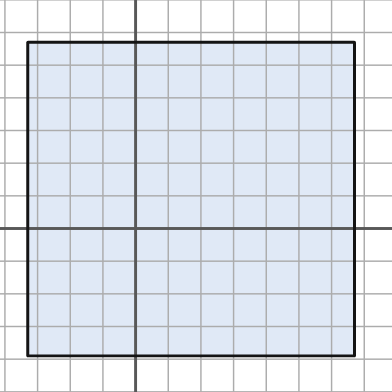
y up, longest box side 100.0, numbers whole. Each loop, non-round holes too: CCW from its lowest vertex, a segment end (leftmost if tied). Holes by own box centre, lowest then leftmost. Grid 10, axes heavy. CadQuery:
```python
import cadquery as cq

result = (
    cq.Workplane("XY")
    .moveTo(-33.0, -39.0)
    .lineTo(67.0, -39.0)
    .lineTo(67.0, 57.0)
    .lineTo(-33.0, 57.0)
    .close()
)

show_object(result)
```